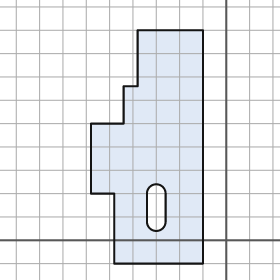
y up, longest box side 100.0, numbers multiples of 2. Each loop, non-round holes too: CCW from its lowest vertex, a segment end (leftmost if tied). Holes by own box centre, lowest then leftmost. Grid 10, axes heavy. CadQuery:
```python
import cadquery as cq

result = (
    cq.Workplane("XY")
    .moveTo(-48.0, -10.0)
    .lineTo(-10.0, -10.0)
    .lineTo(-10.0, 90.0)
    .lineTo(-38.0, 90.0)
    .lineTo(-38.0, 66.0)
    .lineTo(-44.0, 66.0)
    .lineTo(-44.0, 50.0)
    .lineTo(-58.0, 50.0)
    .lineTo(-58.0, 20.0)
    .lineTo(-48.0, 20.0)
    .close()
    .moveTo(-34.0, 8.0)
    .threePointArc((-30.0, 4.0), (-26.0, 8.0))
    .lineTo(-26.0, 20.0)
    .threePointArc((-30.0, 24.0), (-34.0, 20.0))
    .close()
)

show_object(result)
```